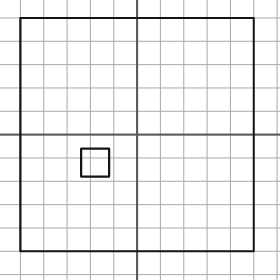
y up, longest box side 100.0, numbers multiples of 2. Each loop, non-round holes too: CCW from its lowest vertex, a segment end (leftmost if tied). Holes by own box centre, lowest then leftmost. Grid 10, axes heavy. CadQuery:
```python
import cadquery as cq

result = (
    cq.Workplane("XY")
    .moveTo(-50.0, -50.0)
    .lineTo(50.0, -50.0)
    .lineTo(50.0, 50.0)
    .lineTo(-50.0, 50.0)
    .close()
    .moveTo(-24.0, -18.0)
    .lineTo(-12.0, -18.0)
    .lineTo(-12.0, -6.0)
    .lineTo(-24.0, -6.0)
    .close()
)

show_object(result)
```